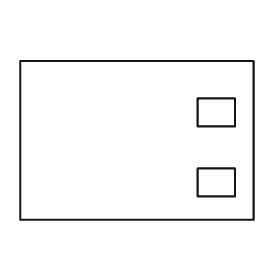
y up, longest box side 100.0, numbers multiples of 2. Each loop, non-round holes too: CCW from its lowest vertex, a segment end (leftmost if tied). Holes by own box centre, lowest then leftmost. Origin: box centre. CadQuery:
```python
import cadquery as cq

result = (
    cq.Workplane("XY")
    .moveTo(-50.0, -34.0)
    .lineTo(50.0, -34.0)
    .lineTo(50.0, 34.0)
    .lineTo(-50.0, 34.0)
    .close()
    .moveTo(26.0, -24.0)
    .lineTo(42.0, -24.0)
    .lineTo(42.0, -12.0)
    .lineTo(26.0, -12.0)
    .close()
    .moveTo(26.0, 6.0)
    .lineTo(42.0, 6.0)
    .lineTo(42.0, 18.0)
    .lineTo(26.0, 18.0)
    .close()
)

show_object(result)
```